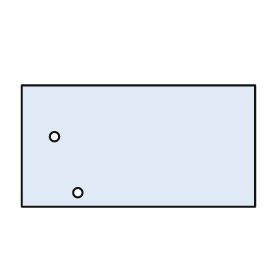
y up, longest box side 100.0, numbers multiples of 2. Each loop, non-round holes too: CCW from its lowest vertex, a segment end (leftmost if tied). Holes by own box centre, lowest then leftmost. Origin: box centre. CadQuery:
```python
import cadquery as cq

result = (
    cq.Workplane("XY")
    .moveTo(-50.0, -26.0)
    .lineTo(50.0, -26.0)
    .lineTo(50.0, 26.0)
    .lineTo(-50.0, 26.0)
    .close()
    .moveTo(-26.0, -20.0)
    .circle(2.0)
    .moveTo(-36.0, 4.0)
    .circle(2.0)
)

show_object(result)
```